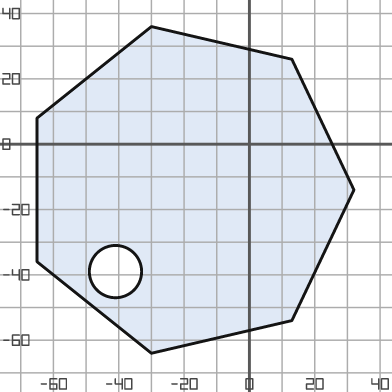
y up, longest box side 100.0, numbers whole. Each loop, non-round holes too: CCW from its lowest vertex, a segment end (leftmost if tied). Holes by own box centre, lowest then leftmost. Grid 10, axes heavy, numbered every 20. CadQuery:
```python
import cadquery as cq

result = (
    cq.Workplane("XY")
    .moveTo(-30.0, -64.0)
    .lineTo(13.0, -54.0)
    .lineTo(32.0, -14.0)
    .lineTo(13.0, 26.0)
    .lineTo(-30.0, 36.0)
    .lineTo(-65.0, 8.0)
    .lineTo(-65.0, -36.0)
    .close()
    .moveTo(-41.0, -39.0)
    .circle(8.0)
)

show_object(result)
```